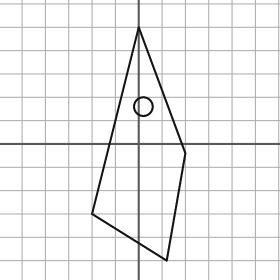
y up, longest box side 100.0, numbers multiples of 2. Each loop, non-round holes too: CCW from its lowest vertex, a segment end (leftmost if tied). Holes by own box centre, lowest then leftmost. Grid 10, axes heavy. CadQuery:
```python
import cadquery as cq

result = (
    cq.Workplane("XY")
    .moveTo(12.0, -50.0)
    .lineTo(20.0, -4.0)
    .lineTo(0.0, 50.0)
    .lineTo(-20.0, -30.0)
    .close()
    .moveTo(2.0, 16.0)
    .circle(4.0)
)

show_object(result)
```